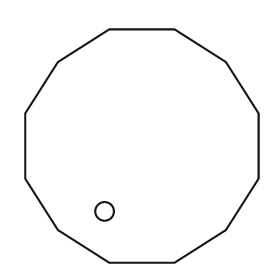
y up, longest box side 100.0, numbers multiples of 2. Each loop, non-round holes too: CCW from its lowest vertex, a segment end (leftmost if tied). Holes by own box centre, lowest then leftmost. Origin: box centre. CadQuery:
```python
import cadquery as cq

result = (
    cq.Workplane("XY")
    .moveTo(-14.0, -50.0)
    .lineTo(14.0, -50.0)
    .lineTo(36.0, -36.0)
    .lineTo(50.0, -14.0)
    .lineTo(50.0, 14.0)
    .lineTo(36.0, 36.0)
    .lineTo(14.0, 50.0)
    .lineTo(-14.0, 50.0)
    .lineTo(-36.0, 36.0)
    .lineTo(-50.0, 14.0)
    .lineTo(-50.0, -14.0)
    .lineTo(-36.0, -36.0)
    .close()
    .moveTo(-16.0, -28.0)
    .circle(4.0)
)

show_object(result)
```